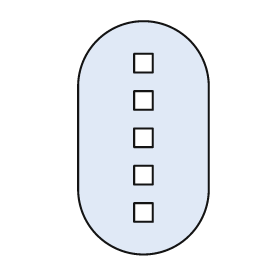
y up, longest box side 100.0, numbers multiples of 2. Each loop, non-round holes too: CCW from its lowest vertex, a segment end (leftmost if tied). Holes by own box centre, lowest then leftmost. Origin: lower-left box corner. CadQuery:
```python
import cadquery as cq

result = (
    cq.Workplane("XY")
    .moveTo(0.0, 28.0)
    .threePointArc((28.0, 0.0), (56.0, 28.0))
    .lineTo(56.0, 72.0)
    .threePointArc((28.0, 100.0), (0.0, 72.0))
    .close()
    .moveTo(24.0, 14.0)
    .lineTo(32.0, 14.0)
    .lineTo(32.0, 22.0)
    .lineTo(24.0, 22.0)
    .close()
    .moveTo(24.0, 30.0)
    .lineTo(32.0, 30.0)
    .lineTo(32.0, 38.0)
    .lineTo(24.0, 38.0)
    .close()
    .moveTo(24.0, 46.0)
    .lineTo(32.0, 46.0)
    .lineTo(32.0, 54.0)
    .lineTo(24.0, 54.0)
    .close()
    .moveTo(24.0, 62.0)
    .lineTo(32.0, 62.0)
    .lineTo(32.0, 70.0)
    .lineTo(24.0, 70.0)
    .close()
    .moveTo(24.0, 78.0)
    .lineTo(32.0, 78.0)
    .lineTo(32.0, 86.0)
    .lineTo(24.0, 86.0)
    .close()
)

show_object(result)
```